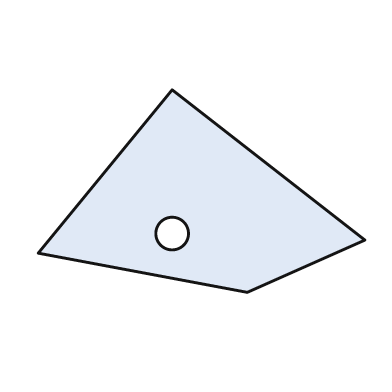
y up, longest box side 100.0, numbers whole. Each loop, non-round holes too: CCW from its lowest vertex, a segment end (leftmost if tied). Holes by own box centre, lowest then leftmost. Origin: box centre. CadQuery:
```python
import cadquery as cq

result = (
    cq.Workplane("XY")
    .moveTo(14.0, -31.0)
    .lineTo(50.0, -15.0)
    .lineTo(-9.0, 31.0)
    .lineTo(-50.0, -19.0)
    .close()
    .moveTo(-9.0, -13.0)
    .circle(5.0)
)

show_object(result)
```